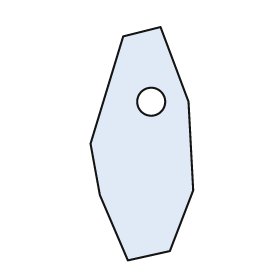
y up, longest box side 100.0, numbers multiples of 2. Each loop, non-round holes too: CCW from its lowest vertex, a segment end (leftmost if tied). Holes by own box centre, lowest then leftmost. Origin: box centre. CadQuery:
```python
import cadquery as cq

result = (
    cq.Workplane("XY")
    .moveTo(-6.0, -50.0)
    .lineTo(12.0, -46.0)
    .lineTo(22.0, -20.0)
    .lineTo(20.0, 18.0)
    .lineTo(8.0, 50.0)
    .lineTo(-8.0, 46.0)
    .lineTo(-22.0, 0.0)
    .lineTo(-18.0, -22.0)
    .close()
    .moveTo(4.0, 18.0)
    .circle(6.0)
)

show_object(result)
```